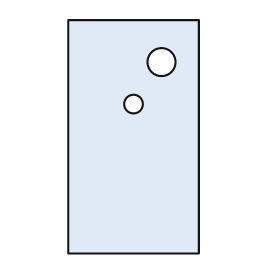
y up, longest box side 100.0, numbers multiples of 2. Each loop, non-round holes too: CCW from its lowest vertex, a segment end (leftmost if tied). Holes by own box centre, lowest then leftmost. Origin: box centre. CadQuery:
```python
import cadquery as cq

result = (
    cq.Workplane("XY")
    .moveTo(-28.0, -50.0)
    .lineTo(28.0, -50.0)
    .lineTo(28.0, 50.0)
    .lineTo(-28.0, 50.0)
    .close()
    .moveTo(0.0, 14.0)
    .circle(4.0)
    .moveTo(12.0, 32.0)
    .circle(6.0)
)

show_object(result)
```